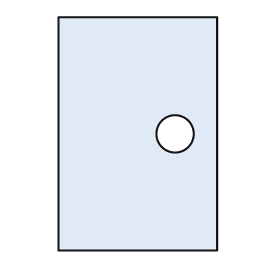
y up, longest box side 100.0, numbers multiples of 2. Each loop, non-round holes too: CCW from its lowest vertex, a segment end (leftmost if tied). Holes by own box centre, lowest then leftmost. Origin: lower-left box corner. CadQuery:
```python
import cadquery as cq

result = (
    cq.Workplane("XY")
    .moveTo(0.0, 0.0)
    .lineTo(68.0, 0.0)
    .lineTo(68.0, 100.0)
    .lineTo(0.0, 100.0)
    .close()
    .moveTo(50.0, 50.0)
    .circle(8.0)
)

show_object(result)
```